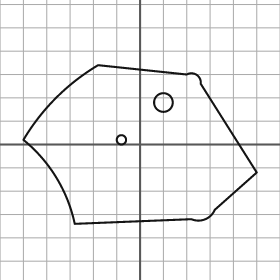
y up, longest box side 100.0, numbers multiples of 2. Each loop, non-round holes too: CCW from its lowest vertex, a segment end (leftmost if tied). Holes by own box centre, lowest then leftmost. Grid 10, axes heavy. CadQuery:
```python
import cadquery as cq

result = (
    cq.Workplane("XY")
    .moveTo(-28.0, -34.0)
    .lineTo(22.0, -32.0)
    .threePointArc((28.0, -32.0), (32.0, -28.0))
    .lineTo(50.0, -12.0)
    .lineTo(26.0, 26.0)
    .threePointArc((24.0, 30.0), (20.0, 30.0))
    .lineTo(-18.0, 34.0)
    .threePointArc((-36.0, 20.0), (-50.0, 2.0))
    .threePointArc((-36.0, -14.0), (-28.0, -34.0))
    .close()
    .moveTo(-8.0, 2.0)
    .circle(2.0)
    .moveTo(10.0, 18.0)
    .circle(4.0)
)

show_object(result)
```